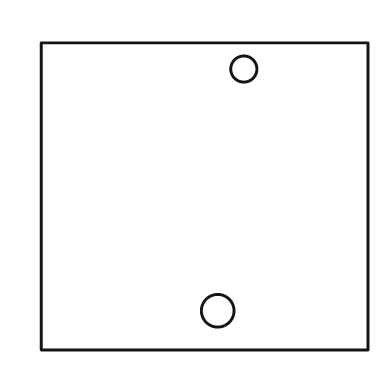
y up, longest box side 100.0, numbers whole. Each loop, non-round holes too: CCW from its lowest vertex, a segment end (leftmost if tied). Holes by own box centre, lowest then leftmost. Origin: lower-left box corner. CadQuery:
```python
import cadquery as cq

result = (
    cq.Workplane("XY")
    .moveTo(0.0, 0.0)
    .lineTo(100.0, 0.0)
    .lineTo(100.0, 94.0)
    .lineTo(0.0, 94.0)
    .close()
    .moveTo(54.0, 12.0)
    .circle(5.0)
    .moveTo(62.0, 86.0)
    .circle(4.0)
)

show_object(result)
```